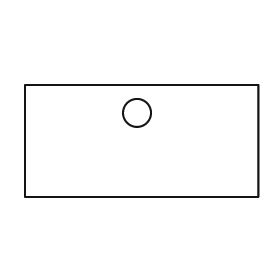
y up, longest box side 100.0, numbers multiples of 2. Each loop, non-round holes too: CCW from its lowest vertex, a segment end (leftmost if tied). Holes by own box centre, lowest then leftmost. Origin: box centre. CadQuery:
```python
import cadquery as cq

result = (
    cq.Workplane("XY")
    .moveTo(-50.0, -24.0)
    .lineTo(50.0, -24.0)
    .lineTo(50.0, 24.0)
    .lineTo(-50.0, 24.0)
    .close()
    .moveTo(-2.0, 12.0)
    .circle(6.0)
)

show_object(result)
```